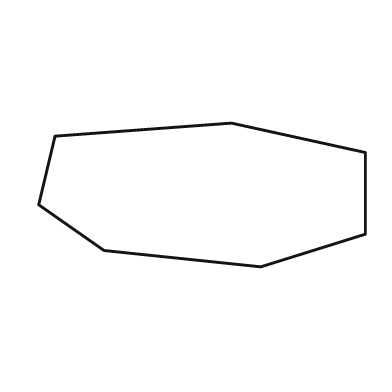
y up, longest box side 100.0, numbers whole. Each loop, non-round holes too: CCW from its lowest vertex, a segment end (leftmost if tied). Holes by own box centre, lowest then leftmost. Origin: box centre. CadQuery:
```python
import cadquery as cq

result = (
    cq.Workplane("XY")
    .moveTo(18.0, -22.0)
    .lineTo(50.0, -12.0)
    .lineTo(50.0, 13.0)
    .lineTo(9.0, 22.0)
    .lineTo(-45.0, 18.0)
    .lineTo(-50.0, -3.0)
    .lineTo(-30.0, -17.0)
    .close()
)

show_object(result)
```